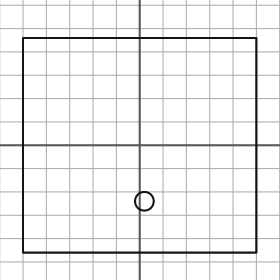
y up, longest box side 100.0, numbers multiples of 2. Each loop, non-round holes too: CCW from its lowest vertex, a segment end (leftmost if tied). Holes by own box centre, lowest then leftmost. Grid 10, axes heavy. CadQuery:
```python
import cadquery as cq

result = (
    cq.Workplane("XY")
    .moveTo(-50.0, -46.0)
    .lineTo(50.0, -46.0)
    .lineTo(50.0, 46.0)
    .lineTo(-50.0, 46.0)
    .close()
    .moveTo(2.0, -24.0)
    .circle(4.0)
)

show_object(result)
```